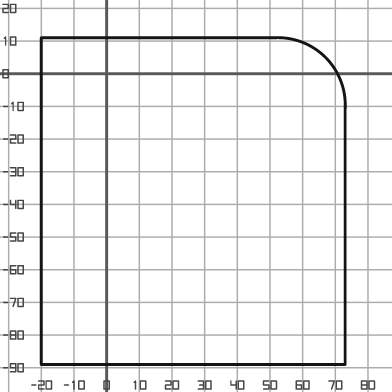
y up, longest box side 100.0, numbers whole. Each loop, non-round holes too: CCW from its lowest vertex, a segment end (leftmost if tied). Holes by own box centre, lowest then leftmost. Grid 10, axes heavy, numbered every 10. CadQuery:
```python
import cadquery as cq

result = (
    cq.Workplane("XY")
    .moveTo(-20.0, -89.0)
    .lineTo(73.0, -89.0)
    .lineTo(73.0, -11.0)
    .threePointArc((67.0, 5.0), (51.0, 11.0))
    .lineTo(-20.0, 11.0)
    .close()
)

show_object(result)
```